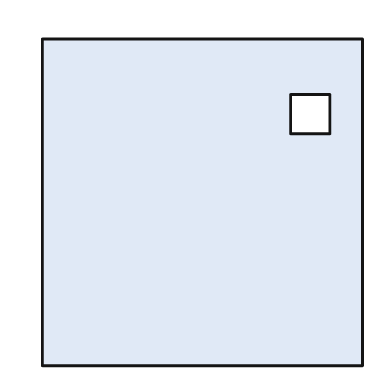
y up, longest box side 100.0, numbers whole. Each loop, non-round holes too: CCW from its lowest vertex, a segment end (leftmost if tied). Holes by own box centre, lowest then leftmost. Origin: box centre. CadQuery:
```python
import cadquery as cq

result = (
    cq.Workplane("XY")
    .moveTo(-49.0, -50.0)
    .lineTo(49.0, -50.0)
    .lineTo(49.0, 50.0)
    .lineTo(-49.0, 50.0)
    .close()
    .moveTo(27.0, 21.0)
    .lineTo(39.0, 21.0)
    .lineTo(39.0, 33.0)
    .lineTo(27.0, 33.0)
    .close()
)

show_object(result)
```